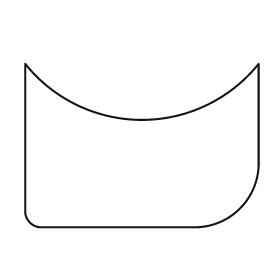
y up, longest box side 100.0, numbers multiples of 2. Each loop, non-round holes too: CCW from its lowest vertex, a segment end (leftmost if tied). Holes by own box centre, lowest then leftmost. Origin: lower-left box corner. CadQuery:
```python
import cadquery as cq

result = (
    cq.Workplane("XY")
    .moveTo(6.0, 0.0)
    .lineTo(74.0, 0.0)
    .threePointArc((92.0, 8.0), (100.0, 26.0))
    .lineTo(100.0, 70.0)
    .threePointArc((50.0, 46.0), (0.0, 70.0))
    .lineTo(0.0, 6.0)
    .threePointArc((2.0, 2.0), (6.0, 0.0))
    .close()
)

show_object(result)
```